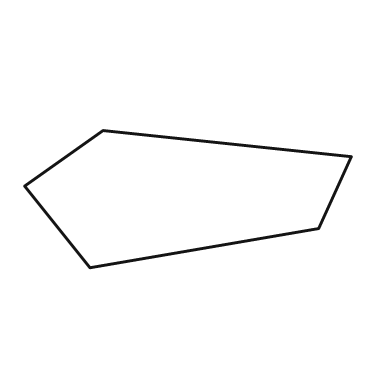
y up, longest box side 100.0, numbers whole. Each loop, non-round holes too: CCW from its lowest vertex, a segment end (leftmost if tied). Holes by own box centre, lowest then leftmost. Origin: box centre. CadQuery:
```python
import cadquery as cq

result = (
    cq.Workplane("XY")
    .moveTo(-30.0, -21.0)
    .lineTo(40.0, -9.0)
    .lineTo(50.0, 13.0)
    .lineTo(-26.0, 21.0)
    .lineTo(-50.0, 4.0)
    .close()
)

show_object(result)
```